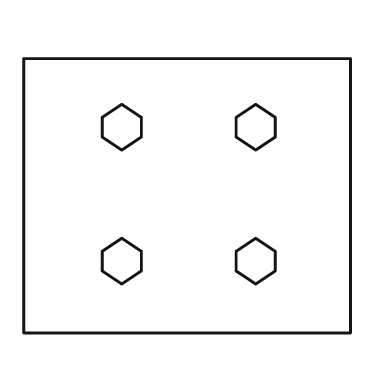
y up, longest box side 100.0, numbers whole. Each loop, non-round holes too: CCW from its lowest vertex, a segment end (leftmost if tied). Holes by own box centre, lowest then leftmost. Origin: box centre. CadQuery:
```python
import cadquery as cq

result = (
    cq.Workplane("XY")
    .moveTo(-50.0, -42.0)
    .lineTo(50.0, -42.0)
    .lineTo(50.0, 42.0)
    .lineTo(-50.0, 42.0)
    .close()
    .moveTo(-20.0, -27.0)
    .lineTo(-14.0, -23.0)
    .lineTo(-14.0, -17.0)
    .lineTo(-20.0, -13.0)
    .lineTo(-26.0, -17.0)
    .lineTo(-26.0, -23.0)
    .close()
    .moveTo(21.0, -27.0)
    .lineTo(27.0, -23.0)
    .lineTo(27.0, -17.0)
    .lineTo(21.0, -13.0)
    .lineTo(15.0, -17.0)
    .lineTo(15.0, -23.0)
    .close()
    .moveTo(-20.0, 14.0)
    .lineTo(-14.0, 18.0)
    .lineTo(-14.0, 24.0)
    .lineTo(-20.0, 28.0)
    .lineTo(-26.0, 24.0)
    .lineTo(-26.0, 18.0)
    .close()
    .moveTo(21.0, 14.0)
    .lineTo(27.0, 18.0)
    .lineTo(27.0, 24.0)
    .lineTo(21.0, 28.0)
    .lineTo(15.0, 24.0)
    .lineTo(15.0, 18.0)
    .close()
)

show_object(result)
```